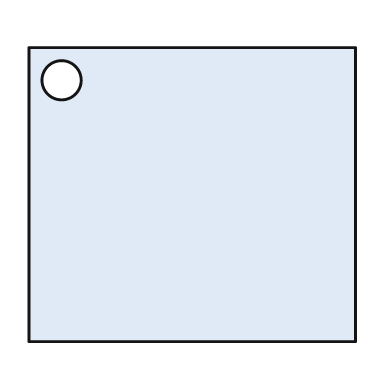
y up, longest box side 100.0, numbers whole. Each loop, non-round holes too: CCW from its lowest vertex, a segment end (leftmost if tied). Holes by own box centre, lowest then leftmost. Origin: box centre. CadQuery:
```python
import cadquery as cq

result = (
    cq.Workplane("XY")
    .moveTo(-50.0, -45.0)
    .lineTo(50.0, -45.0)
    .lineTo(50.0, 45.0)
    .lineTo(-50.0, 45.0)
    .close()
    .moveTo(-40.0, 35.0)
    .circle(6.0)
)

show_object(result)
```